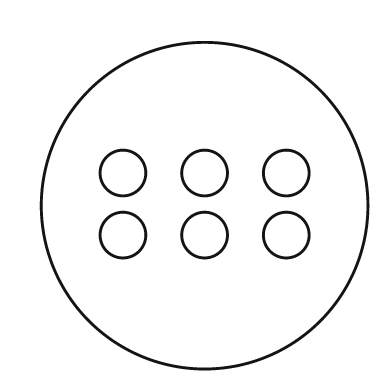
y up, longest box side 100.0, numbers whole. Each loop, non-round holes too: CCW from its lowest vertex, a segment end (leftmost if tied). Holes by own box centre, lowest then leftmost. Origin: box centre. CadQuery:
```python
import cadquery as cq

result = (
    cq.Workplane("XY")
    .moveTo(0.0, 0.0)
    .circle(50.0)
    .moveTo(-25.0, -9.0)
    .circle(7.0)
    .moveTo(0.0, -9.0)
    .circle(7.0)
    .moveTo(25.0, -9.0)
    .circle(7.0)
    .moveTo(-25.0, 10.0)
    .circle(7.0)
    .moveTo(0.0, 10.0)
    .circle(7.0)
    .moveTo(25.0, 10.0)
    .circle(7.0)
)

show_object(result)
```